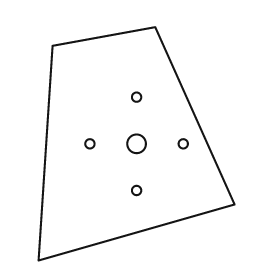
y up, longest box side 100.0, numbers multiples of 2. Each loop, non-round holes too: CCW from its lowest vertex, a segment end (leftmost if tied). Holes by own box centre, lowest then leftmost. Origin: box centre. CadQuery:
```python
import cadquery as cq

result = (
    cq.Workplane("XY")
    .moveTo(-42.0, -50.0)
    .lineTo(42.0, -26.0)
    .lineTo(8.0, 50.0)
    .lineTo(-36.0, 42.0)
    .close()
    .moveTo(0.0, -20.0)
    .circle(2.0)
    .moveTo(-20.0, 0.0)
    .circle(2.0)
    .moveTo(0.0, 0.0)
    .circle(4.0)
    .moveTo(20.0, 0.0)
    .circle(2.0)
    .moveTo(0.0, 20.0)
    .circle(2.0)
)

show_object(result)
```